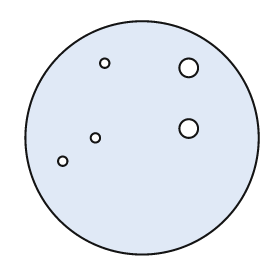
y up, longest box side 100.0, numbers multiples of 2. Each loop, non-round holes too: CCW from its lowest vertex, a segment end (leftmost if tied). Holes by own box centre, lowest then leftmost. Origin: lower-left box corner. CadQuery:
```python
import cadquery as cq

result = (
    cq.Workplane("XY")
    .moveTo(50.0, 50.0)
    .circle(50.0)
    .moveTo(16.0, 40.0)
    .circle(2.0)
    .moveTo(30.0, 50.0)
    .circle(2.0)
    .moveTo(70.0, 54.0)
    .circle(4.0)
    .moveTo(70.0, 80.0)
    .circle(4.0)
    .moveTo(34.0, 82.0)
    .circle(2.0)
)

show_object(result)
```